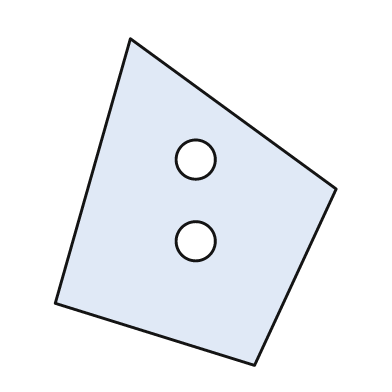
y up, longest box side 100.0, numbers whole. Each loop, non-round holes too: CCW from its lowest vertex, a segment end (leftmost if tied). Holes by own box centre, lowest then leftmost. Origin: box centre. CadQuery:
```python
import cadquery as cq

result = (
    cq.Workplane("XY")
    .moveTo(18.0, -50.0)
    .lineTo(43.0, 4.0)
    .lineTo(-20.0, 50.0)
    .lineTo(-43.0, -31.0)
    .close()
    .moveTo(0.0, -12.0)
    .circle(6.0)
    .moveTo(0.0, 13.0)
    .circle(6.0)
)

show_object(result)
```